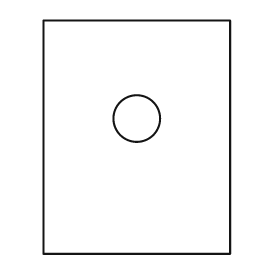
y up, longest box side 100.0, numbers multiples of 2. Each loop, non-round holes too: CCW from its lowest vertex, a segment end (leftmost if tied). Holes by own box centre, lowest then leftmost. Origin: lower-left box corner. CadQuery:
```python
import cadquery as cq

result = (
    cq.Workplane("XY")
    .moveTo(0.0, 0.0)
    .lineTo(80.0, 0.0)
    .lineTo(80.0, 100.0)
    .lineTo(0.0, 100.0)
    .close()
    .moveTo(40.0, 58.0)
    .circle(10.0)
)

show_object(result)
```